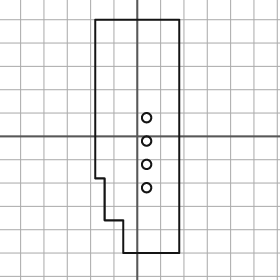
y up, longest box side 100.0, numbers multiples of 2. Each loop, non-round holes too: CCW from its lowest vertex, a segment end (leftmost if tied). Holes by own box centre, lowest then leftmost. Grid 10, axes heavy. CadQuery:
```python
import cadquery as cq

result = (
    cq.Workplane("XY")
    .moveTo(-6.0, -50.0)
    .lineTo(18.0, -50.0)
    .lineTo(18.0, 50.0)
    .lineTo(-18.0, 50.0)
    .lineTo(-18.0, -18.0)
    .lineTo(-14.0, -18.0)
    .lineTo(-14.0, -36.0)
    .lineTo(-6.0, -36.0)
    .close()
    .moveTo(4.0, -22.0)
    .circle(2.0)
    .moveTo(4.0, -12.0)
    .circle(2.0)
    .moveTo(4.0, -2.0)
    .circle(2.0)
    .moveTo(4.0, 8.0)
    .circle(2.0)
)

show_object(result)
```